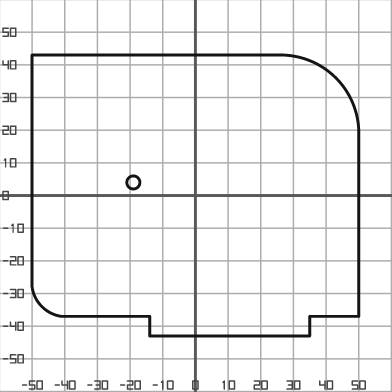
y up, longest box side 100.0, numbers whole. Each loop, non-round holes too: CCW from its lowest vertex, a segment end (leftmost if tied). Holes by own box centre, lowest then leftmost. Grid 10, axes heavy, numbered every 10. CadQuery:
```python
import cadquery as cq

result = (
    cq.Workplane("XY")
    .moveTo(-14.0, -43.0)
    .lineTo(35.0, -43.0)
    .lineTo(35.0, -37.0)
    .lineTo(50.0, -37.0)
    .lineTo(50.0, 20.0)
    .threePointArc((43.0, 36.0), (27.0, 43.0))
    .lineTo(-50.0, 43.0)
    .lineTo(-50.0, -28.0)
    .threePointArc((-47.0, -34.0), (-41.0, -37.0))
    .lineTo(-14.0, -37.0)
    .close()
    .moveTo(-19.0, 4.0)
    .circle(2.0)
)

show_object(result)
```